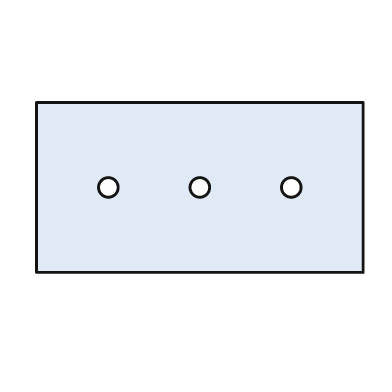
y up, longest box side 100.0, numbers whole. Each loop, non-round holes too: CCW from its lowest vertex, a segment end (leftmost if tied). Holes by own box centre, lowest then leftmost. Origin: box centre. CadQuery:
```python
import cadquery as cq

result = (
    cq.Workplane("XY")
    .moveTo(-50.0, -26.0)
    .lineTo(50.0, -26.0)
    .lineTo(50.0, 26.0)
    .lineTo(-50.0, 26.0)
    .close()
    .moveTo(-28.0, 0.0)
    .circle(3.0)
    .moveTo(0.0, 0.0)
    .circle(3.0)
    .moveTo(28.0, 0.0)
    .circle(3.0)
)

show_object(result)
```